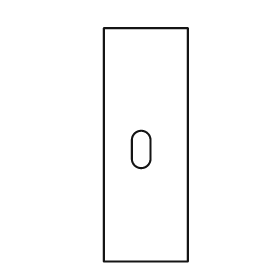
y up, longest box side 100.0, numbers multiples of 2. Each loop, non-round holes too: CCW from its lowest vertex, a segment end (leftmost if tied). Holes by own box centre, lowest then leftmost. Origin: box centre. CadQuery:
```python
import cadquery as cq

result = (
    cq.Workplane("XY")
    .moveTo(-18.0, -50.0)
    .lineTo(18.0, -50.0)
    .lineTo(18.0, 50.0)
    .lineTo(-18.0, 50.0)
    .close()
    .moveTo(-6.0, -6.0)
    .threePointArc((-2.0, -10.0), (2.0, -6.0))
    .lineTo(2.0, 2.0)
    .threePointArc((-2.0, 6.0), (-6.0, 2.0))
    .close()
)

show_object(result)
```